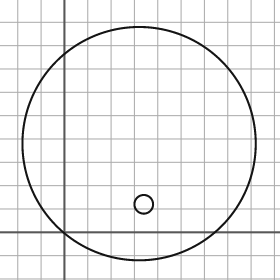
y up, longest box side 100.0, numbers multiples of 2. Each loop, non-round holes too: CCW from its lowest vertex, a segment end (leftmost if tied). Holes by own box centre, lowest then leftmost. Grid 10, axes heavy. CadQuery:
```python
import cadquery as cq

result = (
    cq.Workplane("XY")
    .moveTo(32.0, 38.0)
    .circle(50.0)
    .moveTo(34.0, 12.0)
    .circle(4.0)
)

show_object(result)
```